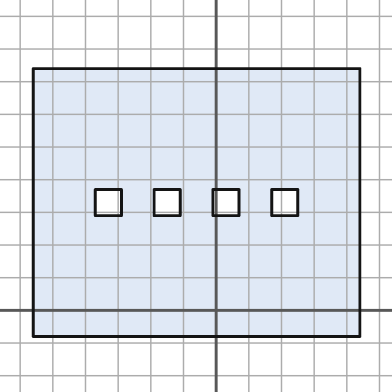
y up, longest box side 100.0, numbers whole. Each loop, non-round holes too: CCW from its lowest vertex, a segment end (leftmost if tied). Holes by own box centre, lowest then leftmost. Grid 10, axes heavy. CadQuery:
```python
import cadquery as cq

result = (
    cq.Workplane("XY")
    .moveTo(-56.0, -8.0)
    .lineTo(44.0, -8.0)
    .lineTo(44.0, 74.0)
    .lineTo(-56.0, 74.0)
    .close()
    .moveTo(-37.0, 29.0)
    .lineTo(-29.0, 29.0)
    .lineTo(-29.0, 37.0)
    .lineTo(-37.0, 37.0)
    .close()
    .moveTo(-19.0, 29.0)
    .lineTo(-11.0, 29.0)
    .lineTo(-11.0, 37.0)
    .lineTo(-19.0, 37.0)
    .close()
    .moveTo(-1.0, 29.0)
    .lineTo(7.0, 29.0)
    .lineTo(7.0, 37.0)
    .lineTo(-1.0, 37.0)
    .close()
    .moveTo(17.0, 29.0)
    .lineTo(25.0, 29.0)
    .lineTo(25.0, 37.0)
    .lineTo(17.0, 37.0)
    .close()
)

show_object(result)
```